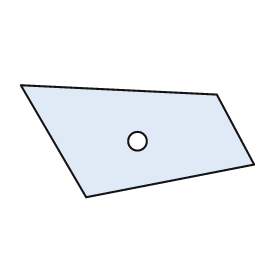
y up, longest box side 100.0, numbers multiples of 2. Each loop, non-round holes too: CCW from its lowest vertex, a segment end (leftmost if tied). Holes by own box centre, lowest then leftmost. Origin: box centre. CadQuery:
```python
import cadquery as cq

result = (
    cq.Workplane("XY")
    .moveTo(-22.0, -24.0)
    .lineTo(50.0, -10.0)
    .lineTo(34.0, 20.0)
    .lineTo(-50.0, 24.0)
    .close()
    .moveTo(0.0, 0.0)
    .circle(4.0)
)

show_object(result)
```